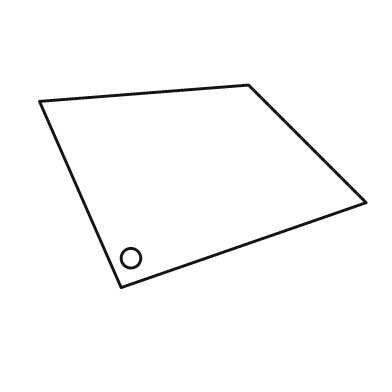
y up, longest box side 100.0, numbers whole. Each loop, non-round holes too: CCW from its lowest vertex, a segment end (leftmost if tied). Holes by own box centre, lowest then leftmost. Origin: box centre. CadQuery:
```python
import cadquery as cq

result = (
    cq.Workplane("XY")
    .moveTo(-25.0, -31.0)
    .lineTo(50.0, -5.0)
    .lineTo(14.0, 31.0)
    .lineTo(-50.0, 26.0)
    .close()
    .moveTo(-22.0, -22.0)
    .circle(3.0)
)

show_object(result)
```